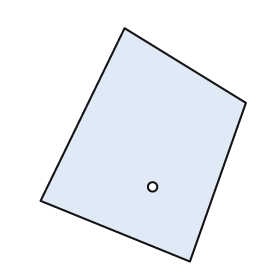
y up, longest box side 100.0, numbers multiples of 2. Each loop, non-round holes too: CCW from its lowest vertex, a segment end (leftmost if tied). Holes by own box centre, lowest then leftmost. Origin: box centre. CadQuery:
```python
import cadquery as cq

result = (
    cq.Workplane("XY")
    .moveTo(20.0, -50.0)
    .lineTo(44.0, 18.0)
    .lineTo(-8.0, 50.0)
    .lineTo(-44.0, -24.0)
    .close()
    .moveTo(4.0, -18.0)
    .circle(2.0)
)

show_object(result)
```